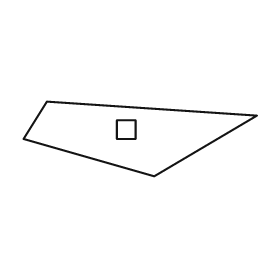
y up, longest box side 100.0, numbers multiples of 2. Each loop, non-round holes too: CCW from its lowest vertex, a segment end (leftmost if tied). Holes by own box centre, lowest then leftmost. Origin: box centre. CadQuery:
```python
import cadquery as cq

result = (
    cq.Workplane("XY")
    .moveTo(6.0, -16.0)
    .lineTo(50.0, 10.0)
    .lineTo(-40.0, 16.0)
    .lineTo(-50.0, 0.0)
    .close()
    .moveTo(-10.0, 0.0)
    .lineTo(-2.0, 0.0)
    .lineTo(-2.0, 8.0)
    .lineTo(-10.0, 8.0)
    .close()
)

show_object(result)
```